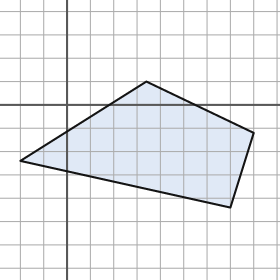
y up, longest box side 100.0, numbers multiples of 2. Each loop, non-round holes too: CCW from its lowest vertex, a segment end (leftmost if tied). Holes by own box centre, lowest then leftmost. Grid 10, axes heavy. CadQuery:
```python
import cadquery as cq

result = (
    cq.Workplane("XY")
    .moveTo(70.0, -44.0)
    .lineTo(80.0, -12.0)
    .lineTo(34.0, 10.0)
    .lineTo(-20.0, -24.0)
    .close()
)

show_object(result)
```